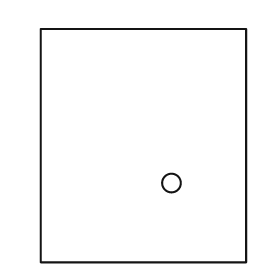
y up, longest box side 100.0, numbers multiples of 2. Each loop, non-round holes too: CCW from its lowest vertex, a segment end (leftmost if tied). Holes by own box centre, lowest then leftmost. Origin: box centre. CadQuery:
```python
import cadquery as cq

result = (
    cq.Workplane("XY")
    .moveTo(-44.0, -50.0)
    .lineTo(44.0, -50.0)
    .lineTo(44.0, 50.0)
    .lineTo(-44.0, 50.0)
    .close()
    .moveTo(12.0, -16.0)
    .circle(4.0)
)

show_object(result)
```